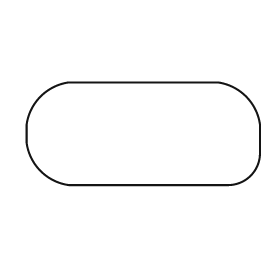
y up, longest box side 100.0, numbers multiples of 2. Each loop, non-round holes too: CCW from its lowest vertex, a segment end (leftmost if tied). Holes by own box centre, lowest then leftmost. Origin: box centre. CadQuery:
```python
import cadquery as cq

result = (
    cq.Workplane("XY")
    .moveTo(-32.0, -22.0)
    .lineTo(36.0, -22.0)
    .threePointArc((46.0, -18.0), (50.0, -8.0))
    .lineTo(50.0, 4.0)
    .threePointArc((44.0, 16.0), (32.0, 22.0))
    .lineTo(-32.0, 22.0)
    .threePointArc((-44.0, 16.0), (-50.0, 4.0))
    .lineTo(-50.0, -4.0)
    .threePointArc((-44.0, -16.0), (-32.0, -22.0))
    .close()
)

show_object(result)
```